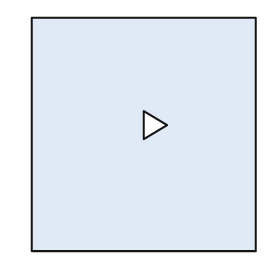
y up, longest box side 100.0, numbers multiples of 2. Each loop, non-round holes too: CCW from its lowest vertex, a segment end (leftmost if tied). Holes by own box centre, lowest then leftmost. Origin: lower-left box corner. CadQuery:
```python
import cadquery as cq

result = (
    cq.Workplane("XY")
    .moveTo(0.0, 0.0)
    .lineTo(96.0, 0.0)
    .lineTo(96.0, 100.0)
    .lineTo(0.0, 100.0)
    .close()
    .moveTo(48.0, 48.0)
    .lineTo(58.0, 54.0)
    .lineTo(48.0, 60.0)
    .close()
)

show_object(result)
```